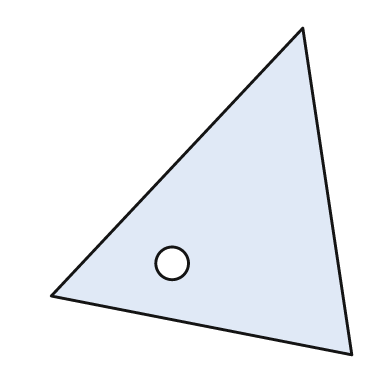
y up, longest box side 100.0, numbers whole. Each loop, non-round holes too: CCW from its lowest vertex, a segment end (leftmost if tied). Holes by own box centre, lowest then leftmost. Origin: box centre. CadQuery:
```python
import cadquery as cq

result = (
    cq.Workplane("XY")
    .moveTo(46.0, -50.0)
    .lineTo(31.0, 50.0)
    .lineTo(-46.0, -32.0)
    .close()
    .moveTo(-9.0, -22.0)
    .circle(5.0)
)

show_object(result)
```